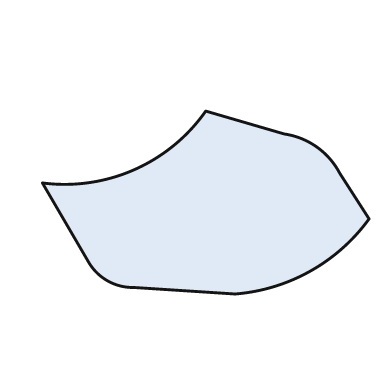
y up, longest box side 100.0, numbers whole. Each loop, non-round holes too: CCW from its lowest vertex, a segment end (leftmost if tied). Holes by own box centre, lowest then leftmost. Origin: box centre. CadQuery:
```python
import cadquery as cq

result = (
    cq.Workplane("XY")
    .moveTo(9.0, -28.0)
    .threePointArc((32.0, -21.0), (50.0, -5.0))
    .lineTo(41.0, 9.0)
    .threePointArc((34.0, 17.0), (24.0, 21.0))
    .lineTo(0.0, 28.0)
    .threePointArc((-22.0, 10.0), (-50.0, 6.0))
    .lineTo(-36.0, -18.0)
    .threePointArc((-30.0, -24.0), (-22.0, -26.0))
    .close()
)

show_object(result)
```